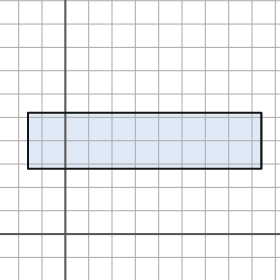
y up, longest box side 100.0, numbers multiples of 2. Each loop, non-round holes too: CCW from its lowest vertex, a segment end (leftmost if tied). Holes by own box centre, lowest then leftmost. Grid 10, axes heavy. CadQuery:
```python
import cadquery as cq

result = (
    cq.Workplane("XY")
    .moveTo(-16.0, 28.0)
    .lineTo(84.0, 28.0)
    .lineTo(84.0, 52.0)
    .lineTo(-16.0, 52.0)
    .close()
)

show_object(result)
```